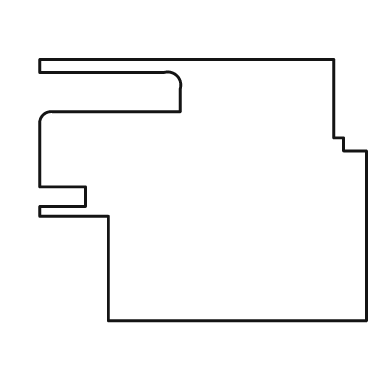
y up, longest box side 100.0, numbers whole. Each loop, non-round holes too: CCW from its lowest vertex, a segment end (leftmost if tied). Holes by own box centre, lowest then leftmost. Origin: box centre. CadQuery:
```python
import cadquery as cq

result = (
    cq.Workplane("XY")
    .moveTo(-29.0, -40.0)
    .lineTo(50.0, -40.0)
    .lineTo(50.0, 12.0)
    .lineTo(43.0, 12.0)
    .lineTo(43.0, 16.0)
    .lineTo(40.0, 16.0)
    .lineTo(40.0, 40.0)
    .lineTo(-50.0, 40.0)
    .lineTo(-50.0, 36.0)
    .lineTo(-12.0, 36.0)
    .threePointArc((-8.0, 35.0), (-7.0, 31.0))
    .lineTo(-7.0, 24.0)
    .lineTo(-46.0, 24.0)
    .threePointArc((-49.0, 23.0), (-50.0, 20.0))
    .lineTo(-50.0, 1.0)
    .lineTo(-36.0, 1.0)
    .lineTo(-36.0, -5.0)
    .lineTo(-50.0, -5.0)
    .lineTo(-50.0, -8.0)
    .lineTo(-29.0, -8.0)
    .close()
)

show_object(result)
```